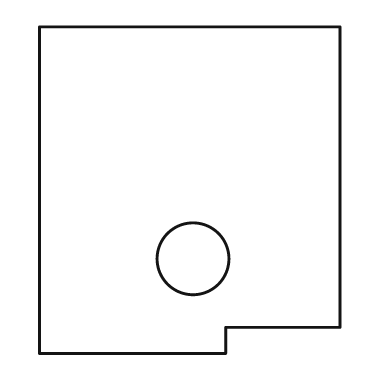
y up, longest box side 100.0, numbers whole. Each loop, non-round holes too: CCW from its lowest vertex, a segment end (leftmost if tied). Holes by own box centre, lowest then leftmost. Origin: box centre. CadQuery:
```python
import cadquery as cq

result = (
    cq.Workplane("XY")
    .moveTo(-46.0, -50.0)
    .lineTo(11.0, -50.0)
    .lineTo(11.0, -42.0)
    .lineTo(46.0, -42.0)
    .lineTo(46.0, 50.0)
    .lineTo(-46.0, 50.0)
    .close()
    .moveTo(1.0, -21.0)
    .circle(11.0)
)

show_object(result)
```